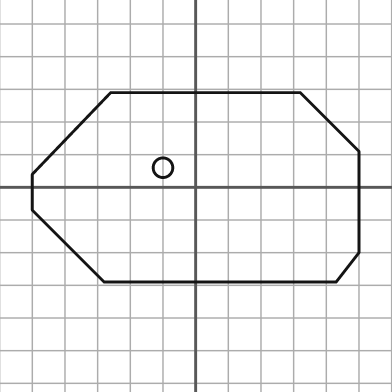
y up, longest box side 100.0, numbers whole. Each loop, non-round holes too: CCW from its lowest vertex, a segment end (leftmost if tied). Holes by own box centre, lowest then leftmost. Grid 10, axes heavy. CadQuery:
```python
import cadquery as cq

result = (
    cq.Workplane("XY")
    .moveTo(-28.0, -29.0)
    .lineTo(43.0, -29.0)
    .lineTo(50.0, -20.0)
    .lineTo(50.0, 11.0)
    .lineTo(32.0, 29.0)
    .lineTo(-26.0, 29.0)
    .lineTo(-50.0, 4.0)
    .lineTo(-50.0, -7.0)
    .close()
    .moveTo(-10.0, 6.0)
    .circle(3.0)
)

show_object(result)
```